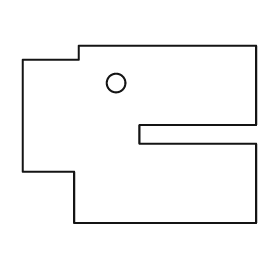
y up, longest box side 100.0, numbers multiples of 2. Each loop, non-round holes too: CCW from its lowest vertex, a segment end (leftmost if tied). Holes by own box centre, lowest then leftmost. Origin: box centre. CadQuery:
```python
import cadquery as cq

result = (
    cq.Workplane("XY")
    .moveTo(-28.0, -38.0)
    .lineTo(50.0, -38.0)
    .lineTo(50.0, -4.0)
    .lineTo(0.0, -4.0)
    .lineTo(0.0, 4.0)
    .lineTo(50.0, 4.0)
    .lineTo(50.0, 38.0)
    .lineTo(-26.0, 38.0)
    .lineTo(-26.0, 32.0)
    .lineTo(-50.0, 32.0)
    .lineTo(-50.0, -16.0)
    .lineTo(-28.0, -16.0)
    .close()
    .moveTo(-10.0, 22.0)
    .circle(4.0)
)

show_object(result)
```